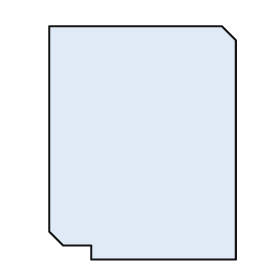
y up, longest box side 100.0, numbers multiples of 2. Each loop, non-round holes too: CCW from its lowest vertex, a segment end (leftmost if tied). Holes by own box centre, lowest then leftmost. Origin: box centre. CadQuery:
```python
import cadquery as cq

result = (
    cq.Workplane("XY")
    .moveTo(-22.0, -50.0)
    .lineTo(40.0, -50.0)
    .lineTo(40.0, 44.0)
    .lineTo(34.0, 50.0)
    .lineTo(-40.0, 50.0)
    .lineTo(-40.0, -38.0)
    .lineTo(-34.0, -44.0)
    .lineTo(-22.0, -44.0)
    .close()
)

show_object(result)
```